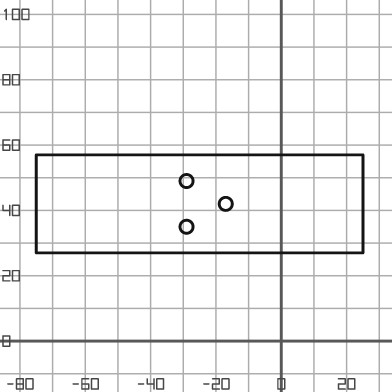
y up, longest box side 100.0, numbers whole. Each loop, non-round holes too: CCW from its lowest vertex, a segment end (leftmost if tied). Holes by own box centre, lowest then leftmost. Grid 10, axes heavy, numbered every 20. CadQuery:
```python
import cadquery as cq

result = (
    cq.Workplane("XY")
    .moveTo(-75.0, 27.0)
    .lineTo(25.0, 27.0)
    .lineTo(25.0, 57.0)
    .lineTo(-75.0, 57.0)
    .close()
    .moveTo(-29.0, 35.0)
    .circle(2.0)
    .moveTo(-17.0, 42.0)
    .circle(2.0)
    .moveTo(-29.0, 49.0)
    .circle(2.0)
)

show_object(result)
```